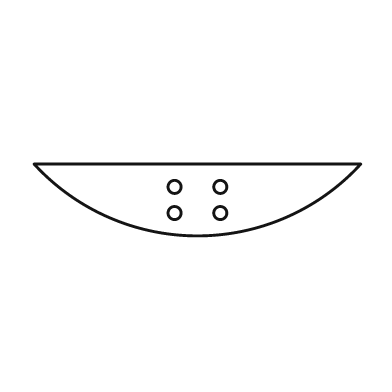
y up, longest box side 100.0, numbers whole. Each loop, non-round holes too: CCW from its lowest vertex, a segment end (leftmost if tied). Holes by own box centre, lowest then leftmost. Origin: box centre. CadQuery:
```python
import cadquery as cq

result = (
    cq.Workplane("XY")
    .moveTo(-50.0, 11.0)
    .threePointArc((0.0, -11.0), (50.0, 11.0))
    .close()
    .moveTo(-7.0, -4.0)
    .circle(2.0)
    .moveTo(7.0, -4.0)
    .circle(2.0)
    .moveTo(-7.0, 4.0)
    .circle(2.0)
    .moveTo(7.0, 4.0)
    .circle(2.0)
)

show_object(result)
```